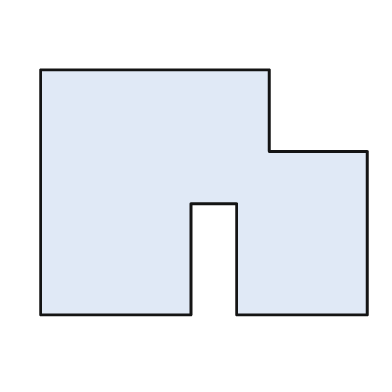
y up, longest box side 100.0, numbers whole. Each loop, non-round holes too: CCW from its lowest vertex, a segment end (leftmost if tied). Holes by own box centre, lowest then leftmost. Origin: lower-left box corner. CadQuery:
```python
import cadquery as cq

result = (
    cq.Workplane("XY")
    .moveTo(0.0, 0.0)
    .lineTo(46.0, 0.0)
    .lineTo(46.0, 34.0)
    .lineTo(60.0, 34.0)
    .lineTo(60.0, 0.0)
    .lineTo(100.0, 0.0)
    .lineTo(100.0, 50.0)
    .lineTo(70.0, 50.0)
    .lineTo(70.0, 75.0)
    .lineTo(0.0, 75.0)
    .close()
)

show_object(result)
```